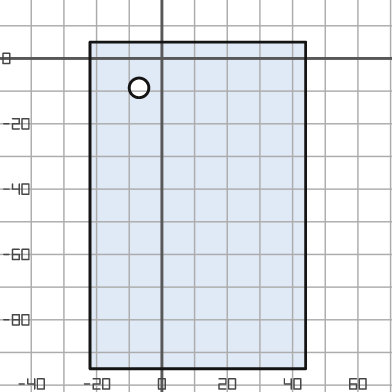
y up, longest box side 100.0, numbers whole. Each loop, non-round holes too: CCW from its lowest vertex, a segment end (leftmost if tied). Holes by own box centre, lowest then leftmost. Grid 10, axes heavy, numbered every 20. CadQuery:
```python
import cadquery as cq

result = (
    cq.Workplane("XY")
    .moveTo(-22.0, -95.0)
    .lineTo(44.0, -95.0)
    .lineTo(44.0, 5.0)
    .lineTo(-22.0, 5.0)
    .close()
    .moveTo(-7.0, -9.0)
    .circle(3.0)
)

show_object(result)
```